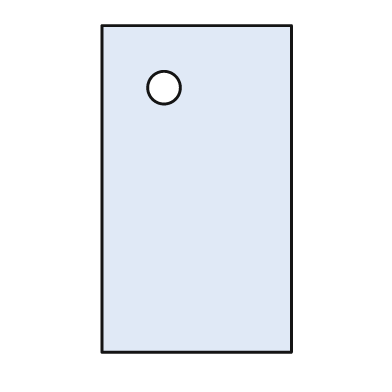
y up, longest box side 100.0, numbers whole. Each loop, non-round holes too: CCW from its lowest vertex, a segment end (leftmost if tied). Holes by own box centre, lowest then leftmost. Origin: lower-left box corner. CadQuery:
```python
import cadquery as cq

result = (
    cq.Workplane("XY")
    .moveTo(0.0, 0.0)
    .lineTo(58.0, 0.0)
    .lineTo(58.0, 100.0)
    .lineTo(0.0, 100.0)
    .close()
    .moveTo(19.0, 81.0)
    .circle(5.0)
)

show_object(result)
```